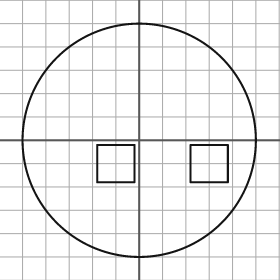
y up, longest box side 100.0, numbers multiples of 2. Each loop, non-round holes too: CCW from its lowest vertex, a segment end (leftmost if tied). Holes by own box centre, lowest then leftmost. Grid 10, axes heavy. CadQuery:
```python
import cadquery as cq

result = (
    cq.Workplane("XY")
    .moveTo(0.0, 0.0)
    .circle(50.0)
    .moveTo(-18.0, -18.0)
    .lineTo(-2.0, -18.0)
    .lineTo(-2.0, -2.0)
    .lineTo(-18.0, -2.0)
    .close()
    .moveTo(22.0, -18.0)
    .lineTo(38.0, -18.0)
    .lineTo(38.0, -2.0)
    .lineTo(22.0, -2.0)
    .close()
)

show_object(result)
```